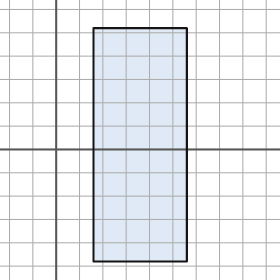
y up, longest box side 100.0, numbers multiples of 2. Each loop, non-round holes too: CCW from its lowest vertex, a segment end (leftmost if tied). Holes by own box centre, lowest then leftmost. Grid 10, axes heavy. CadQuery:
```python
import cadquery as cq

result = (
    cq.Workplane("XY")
    .moveTo(16.0, -48.0)
    .lineTo(56.0, -48.0)
    .lineTo(56.0, 52.0)
    .lineTo(16.0, 52.0)
    .close()
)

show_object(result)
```